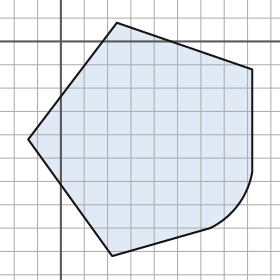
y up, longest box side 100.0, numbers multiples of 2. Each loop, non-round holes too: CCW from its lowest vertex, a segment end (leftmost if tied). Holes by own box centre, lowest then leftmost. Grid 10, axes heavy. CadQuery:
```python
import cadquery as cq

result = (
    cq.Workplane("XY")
    .moveTo(22.0, -92.0)
    .lineTo(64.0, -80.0)
    .threePointArc((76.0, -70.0), (82.0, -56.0))
    .lineTo(82.0, -12.0)
    .lineTo(24.0, 8.0)
    .lineTo(-14.0, -42.0)
    .close()
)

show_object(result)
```